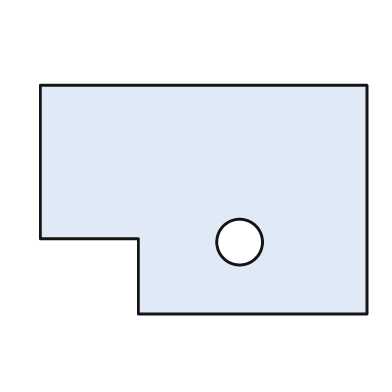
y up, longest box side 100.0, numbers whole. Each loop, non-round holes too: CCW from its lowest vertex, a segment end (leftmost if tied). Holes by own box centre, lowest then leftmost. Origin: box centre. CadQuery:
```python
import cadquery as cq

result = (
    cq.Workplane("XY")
    .moveTo(-20.0, -35.0)
    .lineTo(50.0, -35.0)
    .lineTo(50.0, 35.0)
    .lineTo(-50.0, 35.0)
    .lineTo(-50.0, -12.0)
    .lineTo(-20.0, -12.0)
    .close()
    .moveTo(11.0, -13.0)
    .circle(7.0)
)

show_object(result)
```